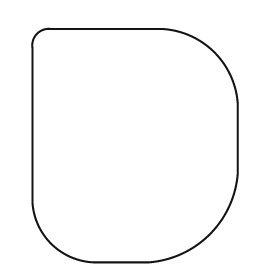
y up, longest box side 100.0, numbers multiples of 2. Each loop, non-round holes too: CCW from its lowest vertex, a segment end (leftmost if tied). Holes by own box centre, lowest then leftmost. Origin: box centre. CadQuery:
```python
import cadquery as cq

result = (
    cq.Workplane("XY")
    .moveTo(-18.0, -50.0)
    .lineTo(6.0, -50.0)
    .threePointArc((32.0, -38.0), (44.0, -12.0))
    .lineTo(44.0, 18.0)
    .threePointArc((34.0, 40.0), (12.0, 50.0))
    .lineTo(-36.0, 50.0)
    .threePointArc((-42.0, 48.0), (-44.0, 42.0))
    .lineTo(-44.0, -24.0)
    .threePointArc((-36.0, -42.0), (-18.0, -50.0))
    .close()
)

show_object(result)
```